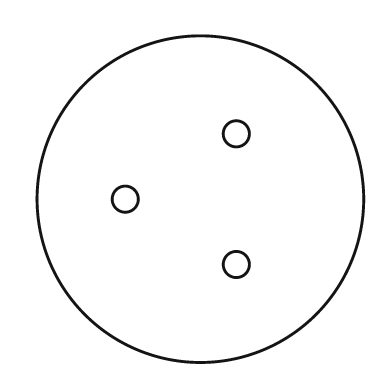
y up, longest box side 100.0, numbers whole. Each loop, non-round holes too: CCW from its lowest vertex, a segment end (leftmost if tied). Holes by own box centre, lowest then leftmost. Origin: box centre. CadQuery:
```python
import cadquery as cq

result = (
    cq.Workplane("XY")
    .moveTo(0.0, 0.0)
    .circle(50.0)
    .moveTo(11.0, -20.0)
    .circle(4.0)
    .moveTo(-23.0, 0.0)
    .circle(4.0)
    .moveTo(11.0, 20.0)
    .circle(4.0)
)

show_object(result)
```